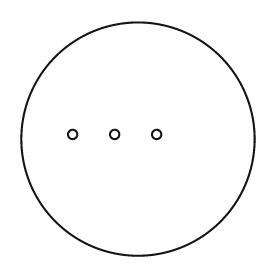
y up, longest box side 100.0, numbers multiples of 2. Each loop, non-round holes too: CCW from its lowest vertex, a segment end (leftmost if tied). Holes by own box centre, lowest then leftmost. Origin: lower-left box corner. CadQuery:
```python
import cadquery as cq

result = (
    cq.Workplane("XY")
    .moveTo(50.0, 50.0)
    .circle(50.0)
    .moveTo(22.0, 52.0)
    .circle(2.0)
    .moveTo(40.0, 52.0)
    .circle(2.0)
    .moveTo(58.0, 52.0)
    .circle(2.0)
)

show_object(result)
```